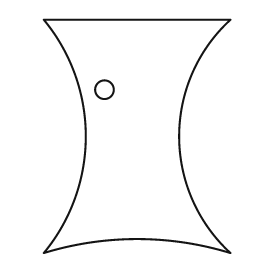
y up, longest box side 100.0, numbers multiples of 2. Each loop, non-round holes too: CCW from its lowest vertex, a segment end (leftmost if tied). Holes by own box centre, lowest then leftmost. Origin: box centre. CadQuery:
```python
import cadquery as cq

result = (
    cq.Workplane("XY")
    .moveTo(-40.0, -50.0)
    .threePointArc((0.0, -44.0), (40.0, -50.0))
    .threePointArc((18.0, 0.0), (40.0, 50.0))
    .lineTo(-40.0, 50.0)
    .threePointArc((-22.0, 0.0), (-40.0, -50.0))
    .close()
    .moveTo(-14.0, 20.0)
    .circle(4.0)
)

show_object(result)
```